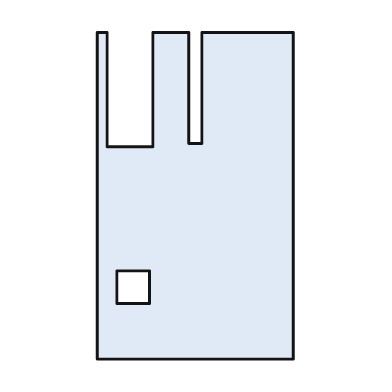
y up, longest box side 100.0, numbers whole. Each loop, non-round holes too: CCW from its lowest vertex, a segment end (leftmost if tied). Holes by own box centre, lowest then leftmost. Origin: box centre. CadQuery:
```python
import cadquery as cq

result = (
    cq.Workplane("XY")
    .moveTo(-30.0, -50.0)
    .lineTo(30.0, -50.0)
    .lineTo(30.0, 50.0)
    .lineTo(2.0, 50.0)
    .lineTo(2.0, 16.0)
    .lineTo(-2.0, 16.0)
    .lineTo(-2.0, 50.0)
    .lineTo(-13.0, 50.0)
    .lineTo(-13.0, 15.0)
    .lineTo(-27.0, 15.0)
    .lineTo(-27.0, 50.0)
    .lineTo(-30.0, 50.0)
    .close()
    .moveTo(-24.0, -33.0)
    .lineTo(-14.0, -33.0)
    .lineTo(-14.0, -23.0)
    .lineTo(-24.0, -23.0)
    .close()
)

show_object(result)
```